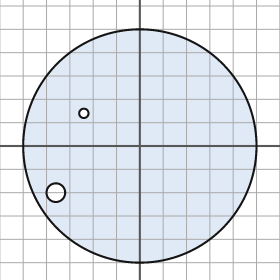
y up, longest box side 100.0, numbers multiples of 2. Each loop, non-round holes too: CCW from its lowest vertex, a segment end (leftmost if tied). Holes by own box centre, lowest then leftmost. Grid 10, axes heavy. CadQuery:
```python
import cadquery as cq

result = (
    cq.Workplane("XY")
    .moveTo(0.0, 0.0)
    .circle(50.0)
    .moveTo(-36.0, -20.0)
    .circle(4.0)
    .moveTo(-24.0, 14.0)
    .circle(2.0)
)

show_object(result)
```